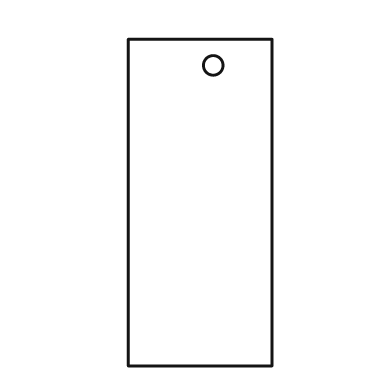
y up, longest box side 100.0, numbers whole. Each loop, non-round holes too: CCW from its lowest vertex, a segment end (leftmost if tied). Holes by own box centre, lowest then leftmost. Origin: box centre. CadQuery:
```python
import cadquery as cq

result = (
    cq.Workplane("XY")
    .moveTo(-22.0, -50.0)
    .lineTo(22.0, -50.0)
    .lineTo(22.0, 50.0)
    .lineTo(-22.0, 50.0)
    .close()
    .moveTo(4.0, 42.0)
    .circle(3.0)
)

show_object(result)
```